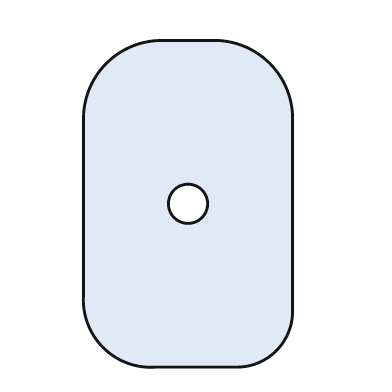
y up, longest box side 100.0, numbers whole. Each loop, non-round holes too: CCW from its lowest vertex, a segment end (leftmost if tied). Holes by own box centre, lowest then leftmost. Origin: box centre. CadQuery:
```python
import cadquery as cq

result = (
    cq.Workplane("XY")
    .moveTo(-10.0, -50.0)
    .lineTo(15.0, -50.0)
    .threePointArc((27.0, -45.0), (32.0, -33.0))
    .lineTo(32.0, 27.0)
    .threePointArc((25.0, 43.0), (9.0, 50.0))
    .lineTo(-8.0, 50.0)
    .threePointArc((-25.0, 43.0), (-32.0, 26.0))
    .lineTo(-32.0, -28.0)
    .threePointArc((-26.0, -44.0), (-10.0, -50.0))
    .close()
    .moveTo(0.0, 0.0)
    .circle(6.0)
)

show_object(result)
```